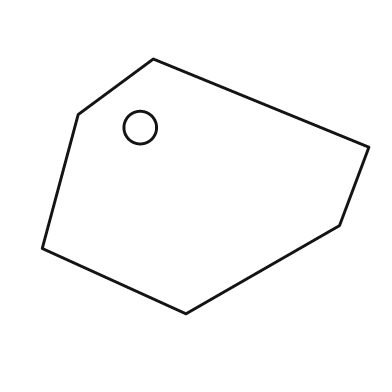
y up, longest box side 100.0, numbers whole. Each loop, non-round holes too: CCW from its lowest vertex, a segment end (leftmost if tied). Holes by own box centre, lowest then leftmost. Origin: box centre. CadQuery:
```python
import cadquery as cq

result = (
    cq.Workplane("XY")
    .moveTo(-6.0, -39.0)
    .lineTo(41.0, -12.0)
    .lineTo(50.0, 12.0)
    .lineTo(-16.0, 39.0)
    .lineTo(-39.0, 22.0)
    .lineTo(-50.0, -19.0)
    .close()
    .moveTo(-20.0, 18.0)
    .circle(5.0)
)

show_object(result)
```